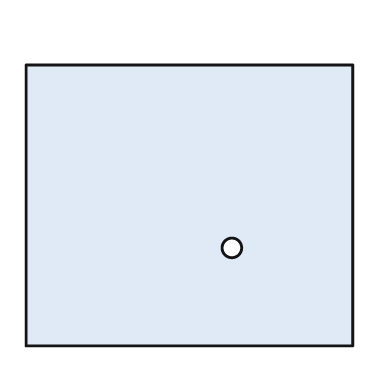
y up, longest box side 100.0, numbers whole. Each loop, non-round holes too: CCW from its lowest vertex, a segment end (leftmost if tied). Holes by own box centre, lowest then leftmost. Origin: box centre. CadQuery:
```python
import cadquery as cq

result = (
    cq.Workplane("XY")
    .moveTo(-50.0, -43.0)
    .lineTo(50.0, -43.0)
    .lineTo(50.0, 43.0)
    .lineTo(-50.0, 43.0)
    .close()
    .moveTo(13.0, -13.0)
    .circle(3.0)
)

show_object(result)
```